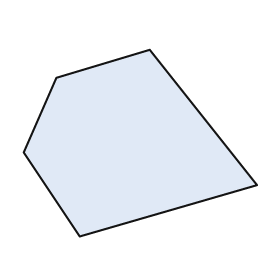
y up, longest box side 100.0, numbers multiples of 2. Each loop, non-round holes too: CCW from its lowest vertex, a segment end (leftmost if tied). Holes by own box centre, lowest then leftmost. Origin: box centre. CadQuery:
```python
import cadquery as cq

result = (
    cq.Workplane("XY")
    .moveTo(-26.0, -40.0)
    .lineTo(50.0, -18.0)
    .lineTo(4.0, 40.0)
    .lineTo(-36.0, 28.0)
    .lineTo(-50.0, -4.0)
    .close()
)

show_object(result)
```